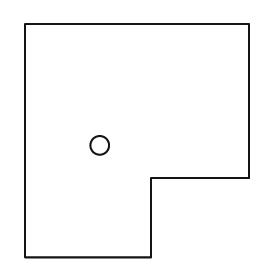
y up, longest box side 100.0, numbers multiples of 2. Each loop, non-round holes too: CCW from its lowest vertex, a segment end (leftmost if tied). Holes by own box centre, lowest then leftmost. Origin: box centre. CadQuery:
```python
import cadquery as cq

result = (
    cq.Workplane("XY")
    .moveTo(-48.0, -50.0)
    .lineTo(6.0, -50.0)
    .lineTo(6.0, -16.0)
    .lineTo(48.0, -16.0)
    .lineTo(48.0, 50.0)
    .lineTo(-48.0, 50.0)
    .close()
    .moveTo(-16.0, -2.0)
    .circle(4.0)
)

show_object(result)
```